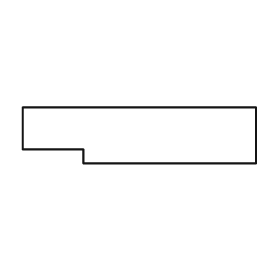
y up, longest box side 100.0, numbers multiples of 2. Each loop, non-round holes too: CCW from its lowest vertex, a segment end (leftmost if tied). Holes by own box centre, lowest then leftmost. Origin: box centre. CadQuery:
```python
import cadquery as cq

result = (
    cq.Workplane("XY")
    .moveTo(-24.0, -12.0)
    .lineTo(50.0, -12.0)
    .lineTo(50.0, 12.0)
    .lineTo(-50.0, 12.0)
    .lineTo(-50.0, -6.0)
    .lineTo(-24.0, -6.0)
    .close()
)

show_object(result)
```